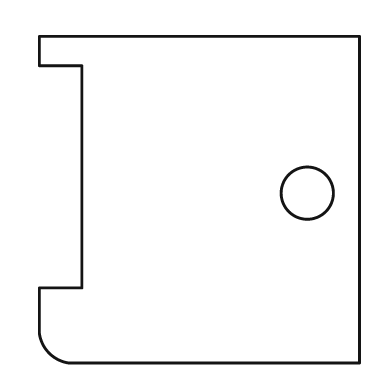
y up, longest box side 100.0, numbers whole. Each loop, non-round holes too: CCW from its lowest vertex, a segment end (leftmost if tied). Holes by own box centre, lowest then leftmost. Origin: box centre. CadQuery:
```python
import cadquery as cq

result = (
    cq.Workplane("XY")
    .moveTo(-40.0, -50.0)
    .lineTo(49.0, -50.0)
    .lineTo(49.0, 50.0)
    .lineTo(-49.0, 50.0)
    .lineTo(-49.0, 41.0)
    .lineTo(-36.0, 41.0)
    .lineTo(-36.0, -27.0)
    .lineTo(-49.0, -27.0)
    .lineTo(-49.0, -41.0)
    .threePointArc((-46.0, -47.0), (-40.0, -50.0))
    .close()
    .moveTo(33.0, 2.0)
    .circle(8.0)
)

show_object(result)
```